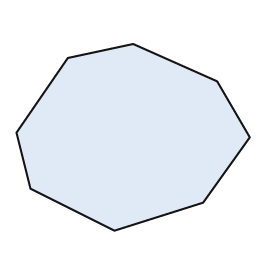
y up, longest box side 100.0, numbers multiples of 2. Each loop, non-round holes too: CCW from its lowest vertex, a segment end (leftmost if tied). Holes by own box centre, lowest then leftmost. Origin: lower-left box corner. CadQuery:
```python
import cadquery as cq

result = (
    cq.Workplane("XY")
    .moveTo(42.0, 0.0)
    .lineTo(80.0, 12.0)
    .lineTo(100.0, 40.0)
    .lineTo(86.0, 64.0)
    .lineTo(50.0, 80.0)
    .lineTo(22.0, 74.0)
    .lineTo(0.0, 42.0)
    .lineTo(6.0, 18.0)
    .close()
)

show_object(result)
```